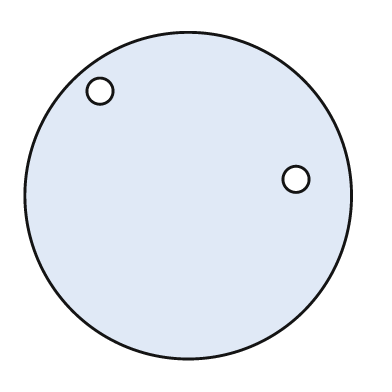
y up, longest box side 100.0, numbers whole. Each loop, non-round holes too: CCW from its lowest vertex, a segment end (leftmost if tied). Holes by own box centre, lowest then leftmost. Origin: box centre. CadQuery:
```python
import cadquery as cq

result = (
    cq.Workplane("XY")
    .moveTo(0.0, 0.0)
    .circle(50.0)
    .moveTo(33.0, 5.0)
    .circle(4.0)
    .moveTo(-27.0, 32.0)
    .circle(4.0)
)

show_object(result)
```